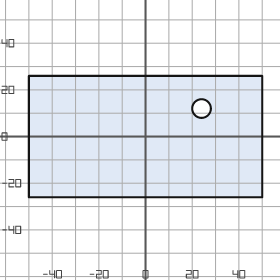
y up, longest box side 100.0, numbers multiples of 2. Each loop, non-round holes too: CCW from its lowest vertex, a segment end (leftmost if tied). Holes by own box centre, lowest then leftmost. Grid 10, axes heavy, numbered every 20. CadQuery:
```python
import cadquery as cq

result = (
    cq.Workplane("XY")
    .moveTo(-50.0, -26.0)
    .lineTo(50.0, -26.0)
    .lineTo(50.0, 26.0)
    .lineTo(-50.0, 26.0)
    .close()
    .moveTo(24.0, 12.0)
    .circle(4.0)
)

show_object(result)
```